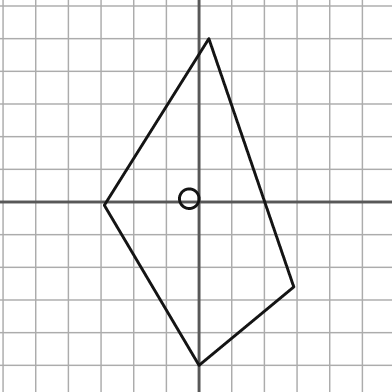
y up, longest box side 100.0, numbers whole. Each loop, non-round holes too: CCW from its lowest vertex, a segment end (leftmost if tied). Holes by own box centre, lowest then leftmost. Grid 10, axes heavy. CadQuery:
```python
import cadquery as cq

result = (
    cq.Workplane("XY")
    .moveTo(0.0, -50.0)
    .lineTo(29.0, -26.0)
    .lineTo(3.0, 50.0)
    .lineTo(-29.0, -1.0)
    .close()
    .moveTo(-3.0, 1.0)
    .circle(3.0)
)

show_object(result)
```